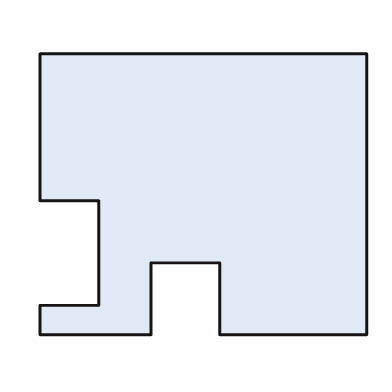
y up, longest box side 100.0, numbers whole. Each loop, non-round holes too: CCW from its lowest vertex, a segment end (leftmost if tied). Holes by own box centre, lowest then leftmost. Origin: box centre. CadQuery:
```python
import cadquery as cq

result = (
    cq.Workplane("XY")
    .moveTo(-50.0, -43.0)
    .lineTo(-16.0, -43.0)
    .lineTo(-16.0, -21.0)
    .lineTo(5.0, -21.0)
    .lineTo(5.0, -43.0)
    .lineTo(50.0, -43.0)
    .lineTo(50.0, 43.0)
    .lineTo(-50.0, 43.0)
    .lineTo(-50.0, -2.0)
    .lineTo(-32.0, -2.0)
    .lineTo(-32.0, -34.0)
    .lineTo(-50.0, -34.0)
    .close()
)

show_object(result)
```